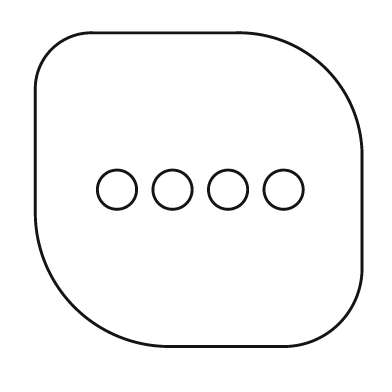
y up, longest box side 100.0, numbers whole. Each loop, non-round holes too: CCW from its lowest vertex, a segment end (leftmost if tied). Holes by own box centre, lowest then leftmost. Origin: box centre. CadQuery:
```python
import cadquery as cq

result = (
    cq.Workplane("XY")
    .moveTo(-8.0, -48.0)
    .lineTo(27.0, -48.0)
    .threePointArc((43.0, -41.0), (50.0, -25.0))
    .lineTo(50.0, 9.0)
    .threePointArc((39.0, 37.0), (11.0, 48.0))
    .lineTo(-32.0, 48.0)
    .threePointArc((-45.0, 43.0), (-50.0, 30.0))
    .lineTo(-50.0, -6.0)
    .threePointArc((-38.0, -36.0), (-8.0, -48.0))
    .close()
    .moveTo(-25.0, 0.0)
    .circle(6.0)
    .moveTo(-8.0, 0.0)
    .circle(6.0)
    .moveTo(9.0, 0.0)
    .circle(6.0)
    .moveTo(26.0, 0.0)
    .circle(6.0)
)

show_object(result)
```